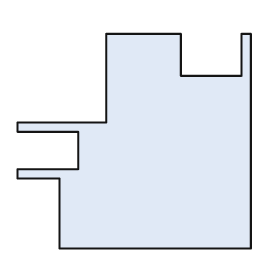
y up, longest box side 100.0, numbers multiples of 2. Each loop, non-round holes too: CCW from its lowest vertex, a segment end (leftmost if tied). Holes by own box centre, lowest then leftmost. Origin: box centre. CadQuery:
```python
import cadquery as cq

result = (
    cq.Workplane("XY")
    .moveTo(-32.0, -46.0)
    .lineTo(50.0, -46.0)
    .lineTo(50.0, 46.0)
    .lineTo(46.0, 46.0)
    .lineTo(46.0, 28.0)
    .lineTo(20.0, 28.0)
    .lineTo(20.0, 46.0)
    .lineTo(-12.0, 46.0)
    .lineTo(-12.0, 8.0)
    .lineTo(-50.0, 8.0)
    .lineTo(-50.0, 4.0)
    .lineTo(-24.0, 4.0)
    .lineTo(-24.0, -12.0)
    .lineTo(-50.0, -12.0)
    .lineTo(-50.0, -16.0)
    .lineTo(-32.0, -16.0)
    .close()
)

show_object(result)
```